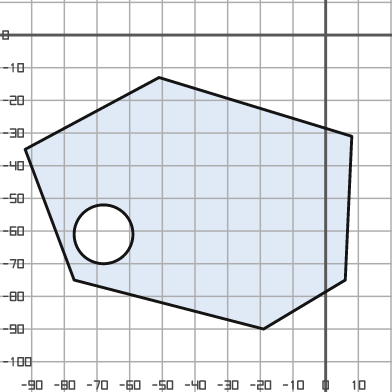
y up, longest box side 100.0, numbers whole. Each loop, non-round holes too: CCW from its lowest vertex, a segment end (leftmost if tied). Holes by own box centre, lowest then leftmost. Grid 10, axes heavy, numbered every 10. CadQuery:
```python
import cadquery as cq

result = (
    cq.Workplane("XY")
    .moveTo(-19.0, -90.0)
    .lineTo(6.0, -75.0)
    .lineTo(8.0, -31.0)
    .lineTo(-51.0, -13.0)
    .lineTo(-92.0, -35.0)
    .lineTo(-77.0, -75.0)
    .close()
    .moveTo(-68.0, -61.0)
    .circle(9.0)
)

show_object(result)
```